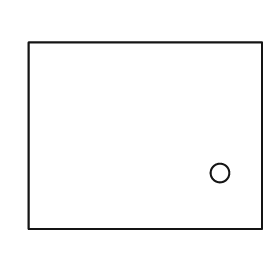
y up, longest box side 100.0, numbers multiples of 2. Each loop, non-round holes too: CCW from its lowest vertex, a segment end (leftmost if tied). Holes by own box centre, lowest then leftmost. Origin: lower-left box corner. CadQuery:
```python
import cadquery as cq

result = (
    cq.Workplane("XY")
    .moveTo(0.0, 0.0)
    .lineTo(100.0, 0.0)
    .lineTo(100.0, 80.0)
    .lineTo(0.0, 80.0)
    .close()
    .moveTo(82.0, 24.0)
    .circle(4.0)
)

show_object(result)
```